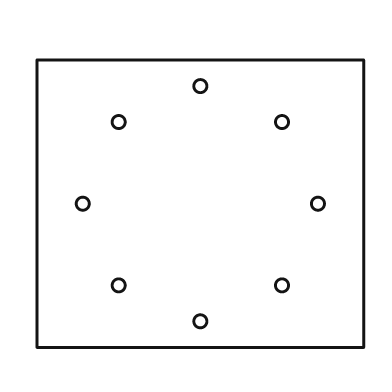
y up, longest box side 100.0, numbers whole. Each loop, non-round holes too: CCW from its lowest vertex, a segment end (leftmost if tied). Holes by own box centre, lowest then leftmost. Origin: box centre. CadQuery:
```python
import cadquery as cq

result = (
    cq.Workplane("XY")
    .moveTo(-50.0, -44.0)
    .lineTo(50.0, -44.0)
    .lineTo(50.0, 44.0)
    .lineTo(-50.0, 44.0)
    .close()
    .moveTo(0.0, -36.0)
    .circle(2.0)
    .moveTo(-25.0, -25.0)
    .circle(2.0)
    .moveTo(25.0, -25.0)
    .circle(2.0)
    .moveTo(-36.0, 0.0)
    .circle(2.0)
    .moveTo(36.0, 0.0)
    .circle(2.0)
    .moveTo(-25.0, 25.0)
    .circle(2.0)
    .moveTo(25.0, 25.0)
    .circle(2.0)
    .moveTo(0.0, 36.0)
    .circle(2.0)
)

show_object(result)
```